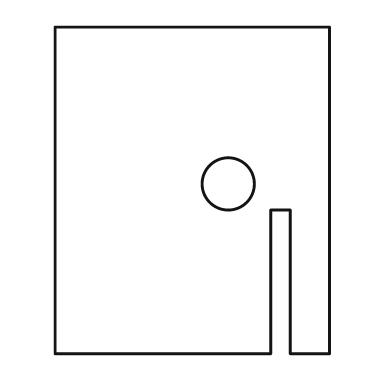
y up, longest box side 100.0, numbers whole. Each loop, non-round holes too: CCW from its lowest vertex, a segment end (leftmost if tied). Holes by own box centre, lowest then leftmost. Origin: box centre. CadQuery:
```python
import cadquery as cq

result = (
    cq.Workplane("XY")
    .moveTo(-42.0, -50.0)
    .lineTo(24.0, -50.0)
    .lineTo(24.0, -6.0)
    .lineTo(30.0, -6.0)
    .lineTo(30.0, -50.0)
    .lineTo(42.0, -50.0)
    .lineTo(42.0, 50.0)
    .lineTo(-42.0, 50.0)
    .close()
    .moveTo(11.0, 2.0)
    .circle(8.0)
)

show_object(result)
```